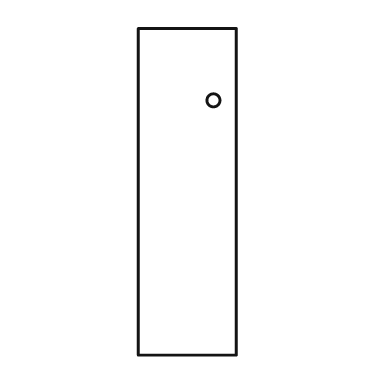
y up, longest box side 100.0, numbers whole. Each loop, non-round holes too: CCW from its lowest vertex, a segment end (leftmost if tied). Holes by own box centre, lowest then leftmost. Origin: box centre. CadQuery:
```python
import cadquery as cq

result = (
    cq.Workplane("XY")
    .moveTo(-15.0, -50.0)
    .lineTo(15.0, -50.0)
    .lineTo(15.0, 50.0)
    .lineTo(-15.0, 50.0)
    .close()
    .moveTo(8.0, 28.0)
    .circle(2.0)
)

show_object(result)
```